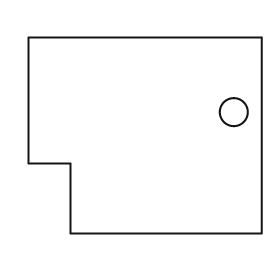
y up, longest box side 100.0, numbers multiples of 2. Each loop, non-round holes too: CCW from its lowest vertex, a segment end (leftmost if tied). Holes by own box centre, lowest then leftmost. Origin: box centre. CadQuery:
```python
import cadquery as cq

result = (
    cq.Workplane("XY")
    .moveTo(-32.0, -42.0)
    .lineTo(50.0, -42.0)
    .lineTo(50.0, 42.0)
    .lineTo(-50.0, 42.0)
    .lineTo(-50.0, -12.0)
    .lineTo(-32.0, -12.0)
    .close()
    .moveTo(38.0, 10.0)
    .circle(6.0)
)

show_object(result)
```